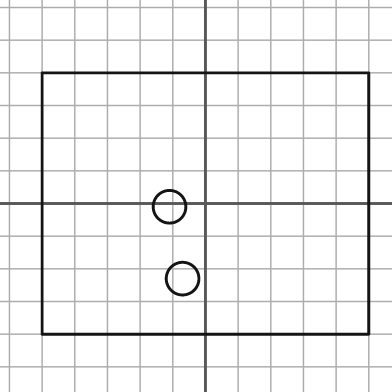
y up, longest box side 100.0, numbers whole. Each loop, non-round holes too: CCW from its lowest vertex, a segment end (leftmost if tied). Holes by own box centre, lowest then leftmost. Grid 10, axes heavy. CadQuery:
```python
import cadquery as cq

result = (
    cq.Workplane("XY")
    .moveTo(-50.0, -40.0)
    .lineTo(50.0, -40.0)
    .lineTo(50.0, 40.0)
    .lineTo(-50.0, 40.0)
    .close()
    .moveTo(-7.0, -23.0)
    .circle(5.0)
    .moveTo(-11.0, -1.0)
    .circle(5.0)
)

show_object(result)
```